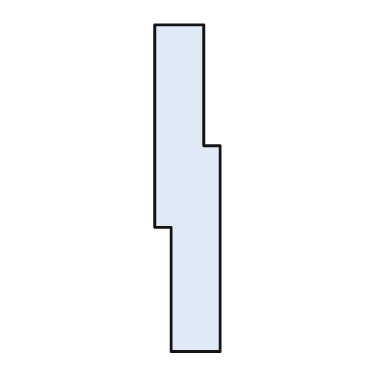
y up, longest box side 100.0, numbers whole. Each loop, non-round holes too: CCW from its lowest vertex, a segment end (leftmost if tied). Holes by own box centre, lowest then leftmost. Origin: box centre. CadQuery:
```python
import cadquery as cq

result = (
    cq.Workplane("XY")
    .moveTo(-5.0, -50.0)
    .lineTo(10.0, -50.0)
    .lineTo(10.0, 13.0)
    .lineTo(5.0, 13.0)
    .lineTo(5.0, 50.0)
    .lineTo(-10.0, 50.0)
    .lineTo(-10.0, -12.0)
    .lineTo(-5.0, -12.0)
    .close()
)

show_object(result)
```